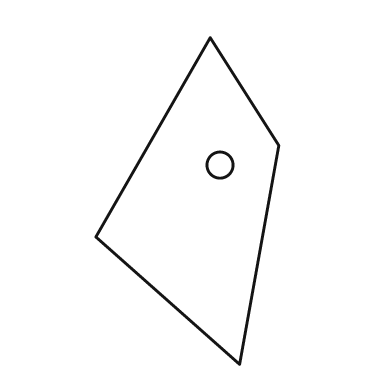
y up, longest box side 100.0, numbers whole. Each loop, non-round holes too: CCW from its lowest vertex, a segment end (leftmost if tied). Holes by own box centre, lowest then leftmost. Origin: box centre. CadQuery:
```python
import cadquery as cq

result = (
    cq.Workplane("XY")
    .moveTo(16.0, -50.0)
    .lineTo(28.0, 17.0)
    .lineTo(7.0, 50.0)
    .lineTo(-28.0, -11.0)
    .close()
    .moveTo(10.0, 11.0)
    .circle(4.0)
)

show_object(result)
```